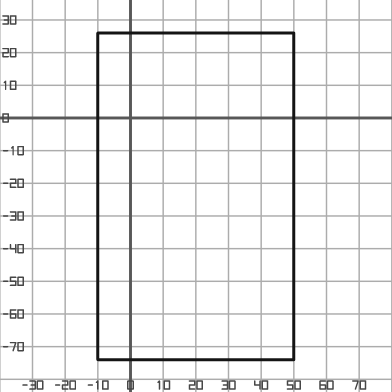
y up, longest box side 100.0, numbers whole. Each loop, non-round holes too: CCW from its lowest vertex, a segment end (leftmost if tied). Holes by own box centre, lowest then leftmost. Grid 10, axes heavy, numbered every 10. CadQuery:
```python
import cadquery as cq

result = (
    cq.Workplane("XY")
    .moveTo(-10.0, -74.0)
    .lineTo(50.0, -74.0)
    .lineTo(50.0, 26.0)
    .lineTo(-10.0, 26.0)
    .close()
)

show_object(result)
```